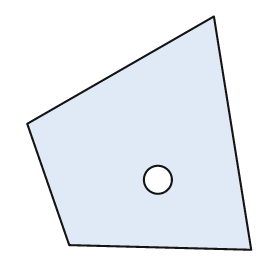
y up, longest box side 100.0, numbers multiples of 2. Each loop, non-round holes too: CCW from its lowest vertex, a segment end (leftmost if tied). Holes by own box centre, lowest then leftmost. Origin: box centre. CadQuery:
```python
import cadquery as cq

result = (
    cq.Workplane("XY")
    .moveTo(48.0, -50.0)
    .lineTo(32.0, 50.0)
    .lineTo(-48.0, 4.0)
    .lineTo(-30.0, -48.0)
    .close()
    .moveTo(8.0, -20.0)
    .circle(6.0)
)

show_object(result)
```